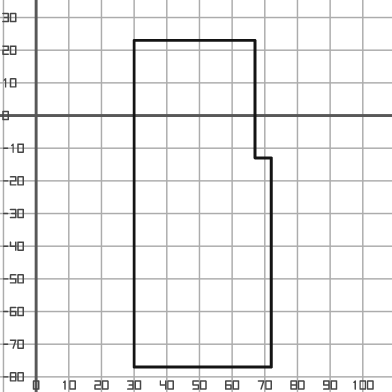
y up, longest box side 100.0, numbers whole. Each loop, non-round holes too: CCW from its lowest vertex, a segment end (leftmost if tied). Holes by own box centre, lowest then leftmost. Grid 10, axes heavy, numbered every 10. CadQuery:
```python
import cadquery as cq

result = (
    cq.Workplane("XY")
    .moveTo(30.0, -77.0)
    .lineTo(72.0, -77.0)
    .lineTo(72.0, -13.0)
    .lineTo(67.0, -13.0)
    .lineTo(67.0, 23.0)
    .lineTo(30.0, 23.0)
    .close()
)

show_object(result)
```